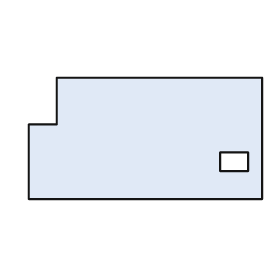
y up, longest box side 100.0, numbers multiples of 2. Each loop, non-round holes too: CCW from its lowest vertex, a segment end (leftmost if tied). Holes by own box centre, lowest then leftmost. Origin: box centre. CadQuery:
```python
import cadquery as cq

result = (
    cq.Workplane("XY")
    .moveTo(-50.0, -26.0)
    .lineTo(50.0, -26.0)
    .lineTo(50.0, 26.0)
    .lineTo(-38.0, 26.0)
    .lineTo(-38.0, 6.0)
    .lineTo(-50.0, 6.0)
    .close()
    .moveTo(32.0, -14.0)
    .lineTo(44.0, -14.0)
    .lineTo(44.0, -6.0)
    .lineTo(32.0, -6.0)
    .close()
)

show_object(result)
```